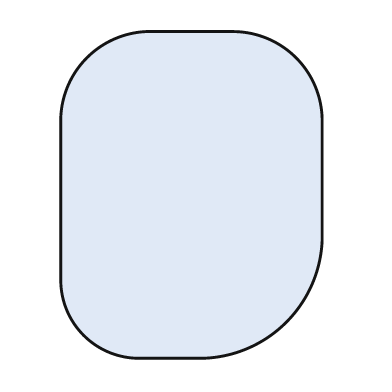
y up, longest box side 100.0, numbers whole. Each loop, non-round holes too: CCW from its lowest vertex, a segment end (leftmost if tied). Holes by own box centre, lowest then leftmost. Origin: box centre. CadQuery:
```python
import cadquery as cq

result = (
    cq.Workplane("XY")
    .moveTo(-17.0, -50.0)
    .lineTo(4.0, -50.0)
    .threePointArc((29.0, -39.0), (40.0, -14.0))
    .lineTo(40.0, 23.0)
    .threePointArc((32.0, 42.0), (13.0, 50.0))
    .lineTo(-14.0, 50.0)
    .threePointArc((-32.0, 42.0), (-40.0, 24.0))
    .lineTo(-40.0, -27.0)
    .threePointArc((-33.0, -43.0), (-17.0, -50.0))
    .close()
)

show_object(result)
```